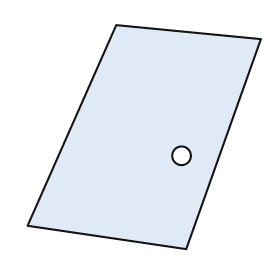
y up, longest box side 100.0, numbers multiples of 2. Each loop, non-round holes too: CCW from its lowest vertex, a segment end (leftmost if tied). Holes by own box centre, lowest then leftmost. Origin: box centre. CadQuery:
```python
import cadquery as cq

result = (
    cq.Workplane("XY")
    .moveTo(18.0, -48.0)
    .lineTo(50.0, 42.0)
    .lineTo(-12.0, 48.0)
    .lineTo(-50.0, -38.0)
    .close()
    .moveTo(16.0, -8.0)
    .circle(4.0)
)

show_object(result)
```